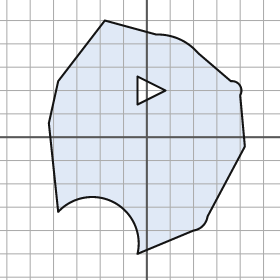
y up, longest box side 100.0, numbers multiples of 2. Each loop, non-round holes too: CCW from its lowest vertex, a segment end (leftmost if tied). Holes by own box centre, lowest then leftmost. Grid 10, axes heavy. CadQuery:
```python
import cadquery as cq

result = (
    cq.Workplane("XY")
    .moveTo(-4.0, -50.0)
    .lineTo(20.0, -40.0)
    .threePointArc((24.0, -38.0), (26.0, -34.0))
    .lineTo(42.0, -4.0)
    .lineTo(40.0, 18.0)
    .threePointArc((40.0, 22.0), (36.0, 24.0))
    .lineTo(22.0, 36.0)
    .threePointArc((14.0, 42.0), (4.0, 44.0))
    .lineTo(-18.0, 50.0)
    .lineTo(-38.0, 24.0)
    .lineTo(-42.0, 6.0)
    .lineTo(-38.0, -32.0)
    .threePointArc((-14.0, -28.0), (-4.0, -50.0))
    .close()
    .moveTo(-4.0, 14.0)
    .lineTo(8.0, 20.0)
    .lineTo(-4.0, 26.0)
    .close()
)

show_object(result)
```